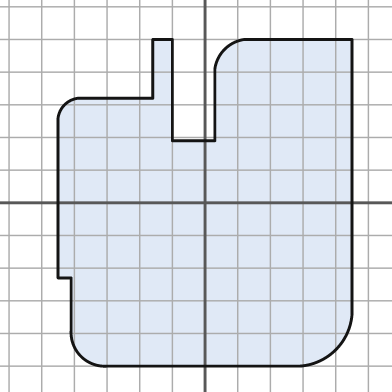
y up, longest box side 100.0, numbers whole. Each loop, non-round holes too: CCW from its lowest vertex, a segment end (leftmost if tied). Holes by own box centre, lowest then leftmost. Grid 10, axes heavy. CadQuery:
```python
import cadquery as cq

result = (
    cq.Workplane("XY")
    .moveTo(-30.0, -50.0)
    .lineTo(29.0, -50.0)
    .threePointArc((40.0, -45.0), (45.0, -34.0))
    .lineTo(45.0, 50.0)
    .lineTo(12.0, 50.0)
    .threePointArc((6.0, 47.0), (3.0, 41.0))
    .lineTo(3.0, 19.0)
    .lineTo(-10.0, 19.0)
    .lineTo(-10.0, 50.0)
    .lineTo(-16.0, 50.0)
    .lineTo(-16.0, 32.0)
    .lineTo(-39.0, 32.0)
    .threePointArc((-43.0, 30.0), (-45.0, 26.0))
    .lineTo(-45.0, -23.0)
    .lineTo(-41.0, -23.0)
    .lineTo(-41.0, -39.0)
    .threePointArc((-38.0, -47.0), (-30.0, -50.0))
    .close()
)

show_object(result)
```